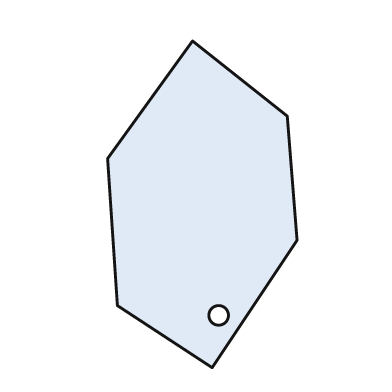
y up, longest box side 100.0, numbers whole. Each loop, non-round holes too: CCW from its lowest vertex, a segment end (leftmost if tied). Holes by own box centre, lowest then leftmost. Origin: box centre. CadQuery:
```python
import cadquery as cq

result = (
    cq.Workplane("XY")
    .moveTo(3.0, -50.0)
    .lineTo(29.0, -11.0)
    .lineTo(26.0, 27.0)
    .lineTo(-3.0, 50.0)
    .lineTo(-29.0, 14.0)
    .lineTo(-26.0, -31.0)
    .close()
    .moveTo(5.0, -34.0)
    .circle(3.0)
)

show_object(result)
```